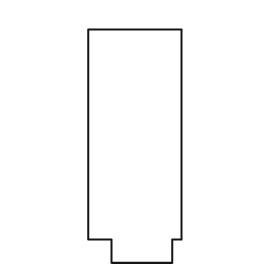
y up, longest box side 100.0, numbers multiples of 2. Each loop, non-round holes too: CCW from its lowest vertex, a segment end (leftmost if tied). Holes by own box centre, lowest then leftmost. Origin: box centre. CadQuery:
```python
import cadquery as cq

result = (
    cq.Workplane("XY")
    .moveTo(-10.0, -50.0)
    .lineTo(16.0, -50.0)
    .lineTo(16.0, -40.0)
    .lineTo(20.0, -40.0)
    .lineTo(20.0, 50.0)
    .lineTo(-20.0, 50.0)
    .lineTo(-20.0, -40.0)
    .lineTo(-10.0, -40.0)
    .close()
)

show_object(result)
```